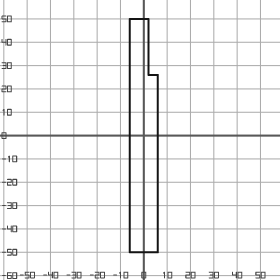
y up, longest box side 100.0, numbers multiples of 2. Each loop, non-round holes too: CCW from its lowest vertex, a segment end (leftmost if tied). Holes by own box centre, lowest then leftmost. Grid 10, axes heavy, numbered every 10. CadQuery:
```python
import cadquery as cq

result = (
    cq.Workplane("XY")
    .moveTo(-6.0, -50.0)
    .lineTo(6.0, -50.0)
    .lineTo(6.0, 26.0)
    .lineTo(2.0, 26.0)
    .lineTo(2.0, 50.0)
    .lineTo(-6.0, 50.0)
    .close()
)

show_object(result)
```